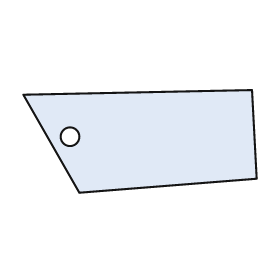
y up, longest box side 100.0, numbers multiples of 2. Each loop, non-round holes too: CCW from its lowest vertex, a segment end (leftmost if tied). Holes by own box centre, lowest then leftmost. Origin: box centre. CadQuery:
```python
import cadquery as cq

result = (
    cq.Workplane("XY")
    .moveTo(-26.0, -22.0)
    .lineTo(50.0, -16.0)
    .lineTo(48.0, 22.0)
    .lineTo(-50.0, 20.0)
    .close()
    .moveTo(-30.0, 2.0)
    .circle(4.0)
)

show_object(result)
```